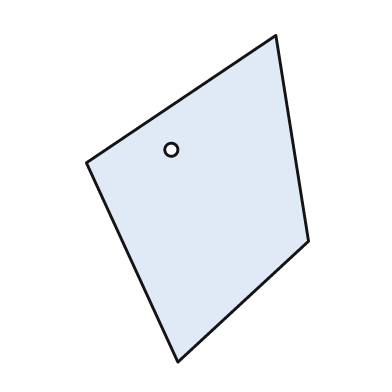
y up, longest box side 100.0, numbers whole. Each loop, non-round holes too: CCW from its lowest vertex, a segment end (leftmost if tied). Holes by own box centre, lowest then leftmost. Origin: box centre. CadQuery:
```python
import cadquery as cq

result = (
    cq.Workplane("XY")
    .moveTo(-6.0, -50.0)
    .lineTo(34.0, -13.0)
    .lineTo(24.0, 50.0)
    .lineTo(-34.0, 11.0)
    .close()
    .moveTo(-8.0, 15.0)
    .circle(2.0)
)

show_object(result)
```